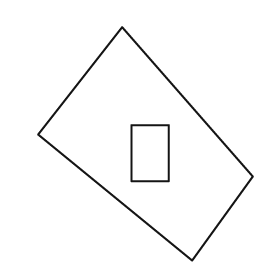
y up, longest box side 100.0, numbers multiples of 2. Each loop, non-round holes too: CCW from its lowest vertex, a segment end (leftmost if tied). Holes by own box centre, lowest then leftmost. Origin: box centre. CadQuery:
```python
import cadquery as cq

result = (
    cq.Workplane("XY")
    .moveTo(20.0, -50.0)
    .lineTo(46.0, -14.0)
    .lineTo(-10.0, 50.0)
    .lineTo(-46.0, 4.0)
    .close()
    .moveTo(-6.0, -16.0)
    .lineTo(10.0, -16.0)
    .lineTo(10.0, 8.0)
    .lineTo(-6.0, 8.0)
    .close()
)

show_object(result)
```